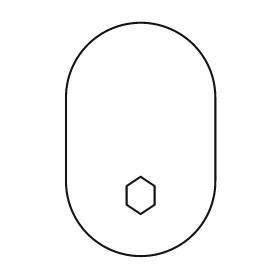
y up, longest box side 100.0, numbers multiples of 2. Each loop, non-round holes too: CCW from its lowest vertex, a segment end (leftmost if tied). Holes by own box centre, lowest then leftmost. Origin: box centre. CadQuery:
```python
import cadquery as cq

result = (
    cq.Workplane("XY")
    .moveTo(-32.0, -18.0)
    .threePointArc((0.0, -50.0), (32.0, -18.0))
    .lineTo(32.0, 18.0)
    .threePointArc((0.0, 50.0), (-32.0, 18.0))
    .close()
    .moveTo(0.0, -32.0)
    .lineTo(6.0, -28.0)
    .lineTo(6.0, -20.0)
    .lineTo(0.0, -16.0)
    .lineTo(-6.0, -20.0)
    .lineTo(-6.0, -28.0)
    .close()
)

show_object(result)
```